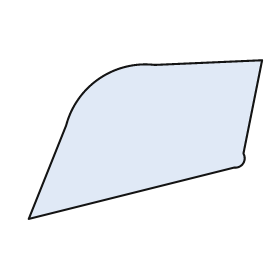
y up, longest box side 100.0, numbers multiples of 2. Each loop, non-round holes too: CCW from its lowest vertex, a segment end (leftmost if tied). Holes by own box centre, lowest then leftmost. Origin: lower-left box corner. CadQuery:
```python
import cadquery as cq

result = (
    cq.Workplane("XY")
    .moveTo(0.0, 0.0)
    .lineTo(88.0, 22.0)
    .threePointArc((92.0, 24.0), (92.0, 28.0))
    .lineTo(100.0, 68.0)
    .lineTo(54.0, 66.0)
    .threePointArc((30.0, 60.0), (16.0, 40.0))
    .close()
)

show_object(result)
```